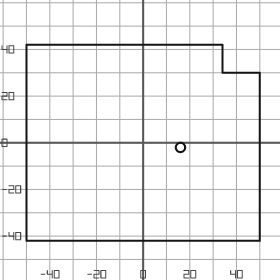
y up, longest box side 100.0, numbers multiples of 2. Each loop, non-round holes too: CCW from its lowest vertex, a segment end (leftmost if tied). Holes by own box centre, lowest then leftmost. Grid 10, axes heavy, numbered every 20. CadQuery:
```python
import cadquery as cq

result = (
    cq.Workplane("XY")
    .moveTo(-50.0, -42.0)
    .lineTo(50.0, -42.0)
    .lineTo(50.0, 30.0)
    .lineTo(34.0, 30.0)
    .lineTo(34.0, 42.0)
    .lineTo(-50.0, 42.0)
    .close()
    .moveTo(16.0, -2.0)
    .circle(2.0)
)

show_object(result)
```